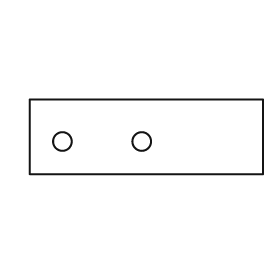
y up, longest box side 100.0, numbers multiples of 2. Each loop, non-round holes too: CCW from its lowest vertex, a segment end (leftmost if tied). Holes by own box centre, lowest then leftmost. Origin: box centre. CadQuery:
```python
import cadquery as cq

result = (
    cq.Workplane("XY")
    .moveTo(-50.0, -16.0)
    .lineTo(50.0, -16.0)
    .lineTo(50.0, 16.0)
    .lineTo(-50.0, 16.0)
    .close()
    .moveTo(-36.0, -2.0)
    .circle(4.0)
    .moveTo(-2.0, -2.0)
    .circle(4.0)
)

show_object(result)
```